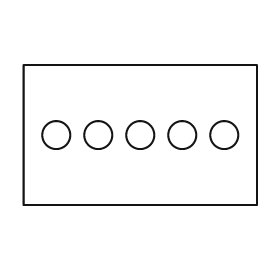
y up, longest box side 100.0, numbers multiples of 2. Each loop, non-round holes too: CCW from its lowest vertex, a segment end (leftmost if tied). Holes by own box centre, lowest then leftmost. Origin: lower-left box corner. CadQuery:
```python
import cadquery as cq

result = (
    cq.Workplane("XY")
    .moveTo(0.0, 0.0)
    .lineTo(100.0, 0.0)
    .lineTo(100.0, 60.0)
    .lineTo(0.0, 60.0)
    .close()
    .moveTo(14.0, 30.0)
    .circle(6.0)
    .moveTo(32.0, 30.0)
    .circle(6.0)
    .moveTo(50.0, 30.0)
    .circle(6.0)
    .moveTo(68.0, 30.0)
    .circle(6.0)
    .moveTo(86.0, 30.0)
    .circle(6.0)
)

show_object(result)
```